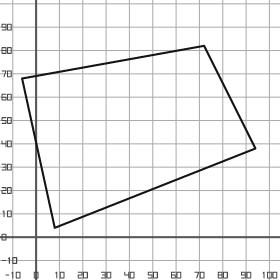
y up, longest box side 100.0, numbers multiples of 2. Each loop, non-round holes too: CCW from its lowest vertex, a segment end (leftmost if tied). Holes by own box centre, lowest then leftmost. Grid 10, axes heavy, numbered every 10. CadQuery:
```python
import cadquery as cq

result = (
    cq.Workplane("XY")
    .moveTo(8.0, 4.0)
    .lineTo(94.0, 38.0)
    .lineTo(72.0, 82.0)
    .lineTo(-6.0, 68.0)
    .close()
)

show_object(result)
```